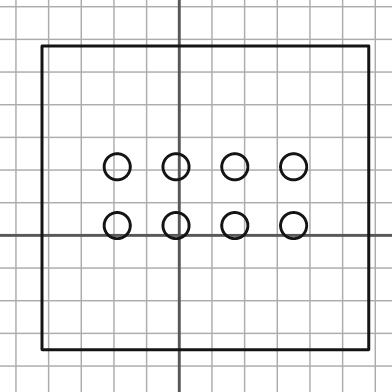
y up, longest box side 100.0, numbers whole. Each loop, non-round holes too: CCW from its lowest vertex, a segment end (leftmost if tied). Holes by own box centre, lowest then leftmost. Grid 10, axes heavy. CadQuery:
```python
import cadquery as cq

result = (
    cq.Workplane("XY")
    .moveTo(-42.0, -35.0)
    .lineTo(58.0, -35.0)
    .lineTo(58.0, 58.0)
    .lineTo(-42.0, 58.0)
    .close()
    .moveTo(-19.0, 3.0)
    .circle(4.0)
    .moveTo(-1.0, 3.0)
    .circle(4.0)
    .moveTo(17.0, 3.0)
    .circle(4.0)
    .moveTo(35.0, 3.0)
    .circle(4.0)
    .moveTo(-19.0, 21.0)
    .circle(4.0)
    .moveTo(-1.0, 21.0)
    .circle(4.0)
    .moveTo(17.0, 21.0)
    .circle(4.0)
    .moveTo(35.0, 21.0)
    .circle(4.0)
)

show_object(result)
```